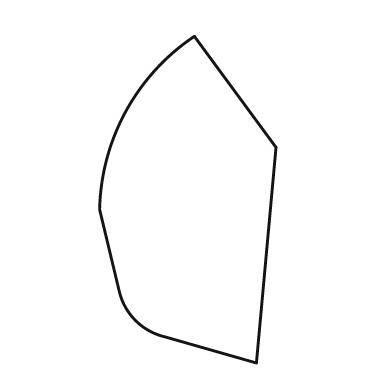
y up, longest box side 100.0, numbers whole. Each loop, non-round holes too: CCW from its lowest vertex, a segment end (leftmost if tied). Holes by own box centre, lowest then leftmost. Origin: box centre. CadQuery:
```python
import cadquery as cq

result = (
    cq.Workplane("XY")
    .moveTo(21.0, -50.0)
    .lineTo(27.0, 16.0)
    .lineTo(2.0, 50.0)
    .threePointArc((-19.0, 27.0), (-27.0, -3.0))
    .lineTo(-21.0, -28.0)
    .threePointArc((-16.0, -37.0), (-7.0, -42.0))
    .close()
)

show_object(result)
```